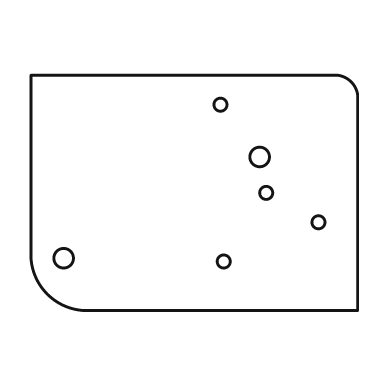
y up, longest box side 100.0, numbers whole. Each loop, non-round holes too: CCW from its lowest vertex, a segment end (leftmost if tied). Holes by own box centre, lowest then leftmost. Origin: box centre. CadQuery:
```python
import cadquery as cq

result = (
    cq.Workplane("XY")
    .moveTo(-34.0, -36.0)
    .lineTo(50.0, -36.0)
    .lineTo(50.0, 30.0)
    .threePointArc((48.0, 34.0), (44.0, 36.0))
    .lineTo(-50.0, 36.0)
    .lineTo(-50.0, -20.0)
    .threePointArc((-45.0, -31.0), (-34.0, -36.0))
    .close()
    .moveTo(9.0, -21.0)
    .circle(2.0)
    .moveTo(-40.0, -20.0)
    .circle(3.0)
    .moveTo(38.0, -9.0)
    .circle(2.0)
    .moveTo(22.0, 0.0)
    .circle(2.0)
    .moveTo(20.0, 11.0)
    .circle(3.0)
    .moveTo(8.0, 27.0)
    .circle(2.0)
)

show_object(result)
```